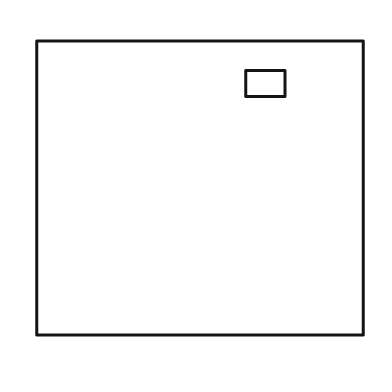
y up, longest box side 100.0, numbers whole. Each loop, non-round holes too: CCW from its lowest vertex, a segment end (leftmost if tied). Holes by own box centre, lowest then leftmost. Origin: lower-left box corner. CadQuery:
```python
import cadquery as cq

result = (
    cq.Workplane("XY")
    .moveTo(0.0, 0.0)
    .lineTo(100.0, 0.0)
    .lineTo(100.0, 90.0)
    .lineTo(0.0, 90.0)
    .close()
    .moveTo(64.0, 73.0)
    .lineTo(76.0, 73.0)
    .lineTo(76.0, 81.0)
    .lineTo(64.0, 81.0)
    .close()
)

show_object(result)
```